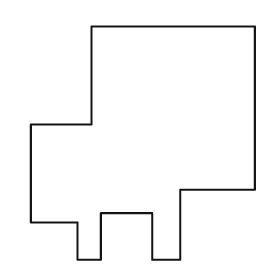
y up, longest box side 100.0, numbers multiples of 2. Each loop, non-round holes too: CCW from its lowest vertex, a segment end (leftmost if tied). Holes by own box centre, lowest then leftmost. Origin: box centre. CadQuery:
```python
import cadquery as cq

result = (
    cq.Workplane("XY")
    .moveTo(-28.0, -50.0)
    .lineTo(-18.0, -50.0)
    .lineTo(-18.0, -30.0)
    .lineTo(4.0, -30.0)
    .lineTo(4.0, -50.0)
    .lineTo(16.0, -50.0)
    .lineTo(16.0, -20.0)
    .lineTo(48.0, -20.0)
    .lineTo(48.0, 50.0)
    .lineTo(-22.0, 50.0)
    .lineTo(-22.0, 8.0)
    .lineTo(-48.0, 8.0)
    .lineTo(-48.0, -34.0)
    .lineTo(-28.0, -34.0)
    .close()
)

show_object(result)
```